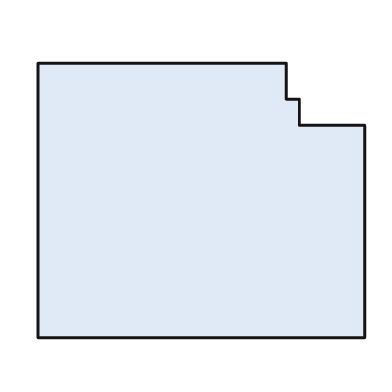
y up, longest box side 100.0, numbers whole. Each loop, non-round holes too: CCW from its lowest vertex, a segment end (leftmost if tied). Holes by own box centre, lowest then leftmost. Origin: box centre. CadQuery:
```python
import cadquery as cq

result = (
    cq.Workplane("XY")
    .moveTo(-50.0, -42.0)
    .lineTo(50.0, -42.0)
    .lineTo(50.0, 23.0)
    .lineTo(30.0, 23.0)
    .lineTo(30.0, 31.0)
    .lineTo(26.0, 31.0)
    .lineTo(26.0, 42.0)
    .lineTo(-50.0, 42.0)
    .close()
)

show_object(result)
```